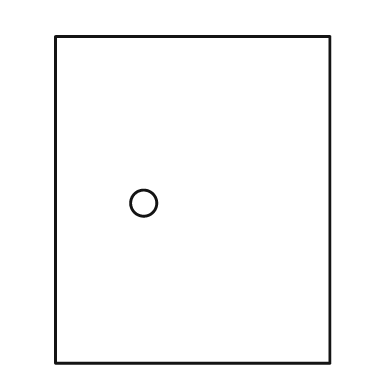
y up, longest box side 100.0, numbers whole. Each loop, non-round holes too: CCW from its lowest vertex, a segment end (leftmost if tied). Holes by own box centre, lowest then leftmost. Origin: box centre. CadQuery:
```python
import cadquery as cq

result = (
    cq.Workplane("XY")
    .moveTo(-42.0, -50.0)
    .lineTo(42.0, -50.0)
    .lineTo(42.0, 50.0)
    .lineTo(-42.0, 50.0)
    .close()
    .moveTo(-15.0, -1.0)
    .circle(4.0)
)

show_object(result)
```